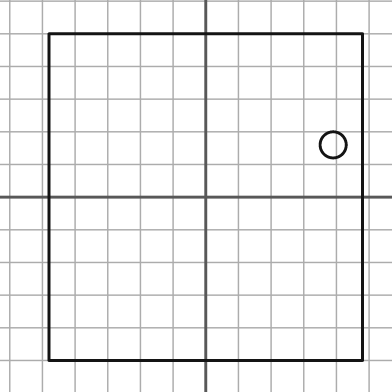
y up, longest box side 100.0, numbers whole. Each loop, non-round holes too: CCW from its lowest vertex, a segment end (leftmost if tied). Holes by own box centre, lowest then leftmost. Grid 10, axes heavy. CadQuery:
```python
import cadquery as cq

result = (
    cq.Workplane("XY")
    .moveTo(-48.0, -50.0)
    .lineTo(48.0, -50.0)
    .lineTo(48.0, 50.0)
    .lineTo(-48.0, 50.0)
    .close()
    .moveTo(39.0, 16.0)
    .circle(4.0)
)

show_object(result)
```